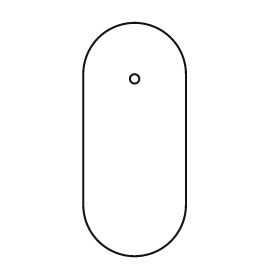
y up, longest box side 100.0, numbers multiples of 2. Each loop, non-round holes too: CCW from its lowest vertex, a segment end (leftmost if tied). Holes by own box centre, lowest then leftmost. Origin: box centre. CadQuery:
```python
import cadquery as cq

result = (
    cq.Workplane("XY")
    .moveTo(-22.0, -28.0)
    .threePointArc((0.0, -50.0), (22.0, -28.0))
    .lineTo(22.0, 28.0)
    .threePointArc((0.0, 50.0), (-22.0, 28.0))
    .close()
    .moveTo(0.0, 26.0)
    .circle(2.0)
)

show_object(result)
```